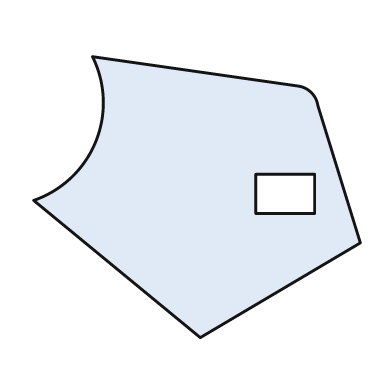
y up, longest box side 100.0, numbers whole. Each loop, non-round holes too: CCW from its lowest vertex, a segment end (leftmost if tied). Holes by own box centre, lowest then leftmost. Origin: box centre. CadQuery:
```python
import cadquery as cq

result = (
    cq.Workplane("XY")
    .moveTo(1.0, -43.0)
    .lineTo(50.0, -14.0)
    .lineTo(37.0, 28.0)
    .threePointArc((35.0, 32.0), (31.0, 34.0))
    .lineTo(-32.0, 43.0)
    .threePointArc((-31.0, 17.0), (-50.0, -1.0))
    .close()
    .moveTo(18.0, -5.0)
    .lineTo(36.0, -5.0)
    .lineTo(36.0, 7.0)
    .lineTo(18.0, 7.0)
    .close()
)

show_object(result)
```